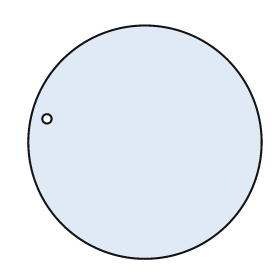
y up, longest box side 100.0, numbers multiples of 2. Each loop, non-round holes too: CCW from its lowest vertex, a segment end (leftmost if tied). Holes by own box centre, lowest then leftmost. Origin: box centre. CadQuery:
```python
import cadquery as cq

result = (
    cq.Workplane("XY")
    .moveTo(0.0, 0.0)
    .circle(50.0)
    .moveTo(-42.0, 10.0)
    .circle(2.0)
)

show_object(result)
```